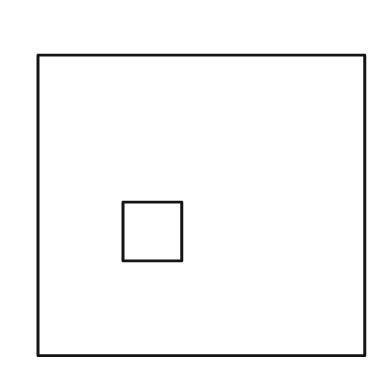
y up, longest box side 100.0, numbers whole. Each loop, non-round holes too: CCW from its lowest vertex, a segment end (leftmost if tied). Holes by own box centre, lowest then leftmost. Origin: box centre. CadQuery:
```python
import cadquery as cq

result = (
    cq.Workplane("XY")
    .moveTo(-50.0, -46.0)
    .lineTo(50.0, -46.0)
    .lineTo(50.0, 46.0)
    .lineTo(-50.0, 46.0)
    .close()
    .moveTo(-24.0, -17.0)
    .lineTo(-6.0, -17.0)
    .lineTo(-6.0, 1.0)
    .lineTo(-24.0, 1.0)
    .close()
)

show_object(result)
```